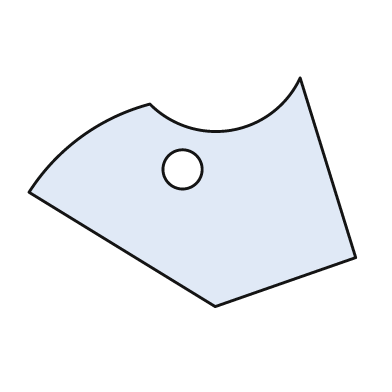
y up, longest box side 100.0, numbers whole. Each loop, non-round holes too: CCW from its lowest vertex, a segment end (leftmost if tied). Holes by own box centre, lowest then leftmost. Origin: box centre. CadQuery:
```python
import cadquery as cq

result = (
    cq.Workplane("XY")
    .moveTo(7.0, -35.0)
    .lineTo(50.0, -20.0)
    .lineTo(33.0, 35.0)
    .threePointArc((12.0, 19.0), (-13.0, 27.0))
    .threePointArc((-34.0, 17.0), (-50.0, 0.0))
    .close()
    .moveTo(-3.0, 7.0)
    .circle(6.0)
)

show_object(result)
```